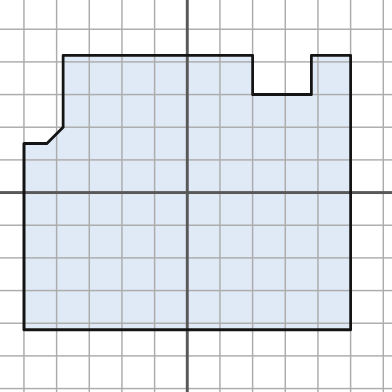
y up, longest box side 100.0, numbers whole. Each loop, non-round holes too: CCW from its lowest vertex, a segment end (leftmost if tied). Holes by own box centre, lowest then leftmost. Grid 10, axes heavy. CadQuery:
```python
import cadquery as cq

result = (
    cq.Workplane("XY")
    .moveTo(-50.0, -42.0)
    .lineTo(50.0, -42.0)
    .lineTo(50.0, 42.0)
    .lineTo(38.0, 42.0)
    .lineTo(38.0, 30.0)
    .lineTo(20.0, 30.0)
    .lineTo(20.0, 42.0)
    .lineTo(-38.0, 42.0)
    .lineTo(-38.0, 20.0)
    .lineTo(-43.0, 15.0)
    .lineTo(-50.0, 15.0)
    .close()
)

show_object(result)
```